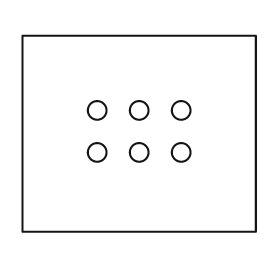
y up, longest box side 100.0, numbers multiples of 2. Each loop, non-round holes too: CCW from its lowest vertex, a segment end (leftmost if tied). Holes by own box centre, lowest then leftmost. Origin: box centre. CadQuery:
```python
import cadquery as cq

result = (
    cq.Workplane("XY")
    .moveTo(-50.0, -42.0)
    .lineTo(50.0, -42.0)
    .lineTo(50.0, 42.0)
    .lineTo(-50.0, 42.0)
    .close()
    .moveTo(-18.0, -8.0)
    .circle(4.0)
    .moveTo(0.0, -8.0)
    .circle(4.0)
    .moveTo(18.0, -8.0)
    .circle(4.0)
    .moveTo(-18.0, 10.0)
    .circle(4.0)
    .moveTo(0.0, 10.0)
    .circle(4.0)
    .moveTo(18.0, 10.0)
    .circle(4.0)
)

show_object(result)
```